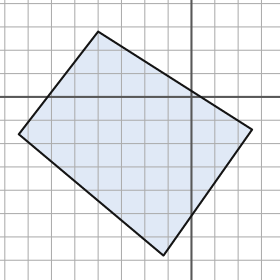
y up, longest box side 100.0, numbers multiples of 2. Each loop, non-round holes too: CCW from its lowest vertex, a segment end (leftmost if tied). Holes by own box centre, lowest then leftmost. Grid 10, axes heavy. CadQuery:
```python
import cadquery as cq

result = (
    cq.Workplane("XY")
    .moveTo(-12.0, -68.0)
    .lineTo(26.0, -14.0)
    .lineTo(-40.0, 28.0)
    .lineTo(-74.0, -16.0)
    .close()
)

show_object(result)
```